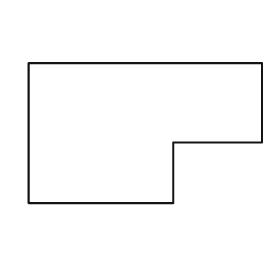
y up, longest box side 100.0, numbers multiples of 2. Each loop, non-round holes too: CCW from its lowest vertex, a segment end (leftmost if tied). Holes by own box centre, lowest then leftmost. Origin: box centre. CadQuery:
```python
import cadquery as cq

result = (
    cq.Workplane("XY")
    .moveTo(-50.0, -30.0)
    .lineTo(12.0, -30.0)
    .lineTo(12.0, -4.0)
    .lineTo(50.0, -4.0)
    .lineTo(50.0, 30.0)
    .lineTo(-50.0, 30.0)
    .close()
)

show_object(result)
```